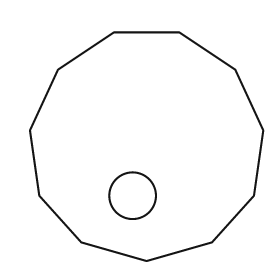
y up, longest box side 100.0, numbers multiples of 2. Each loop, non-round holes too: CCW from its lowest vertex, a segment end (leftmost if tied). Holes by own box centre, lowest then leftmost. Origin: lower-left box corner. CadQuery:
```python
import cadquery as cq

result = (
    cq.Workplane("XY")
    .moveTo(50.0, 0.0)
    .lineTo(78.0, 8.0)
    .lineTo(96.0, 28.0)
    .lineTo(100.0, 56.0)
    .lineTo(88.0, 82.0)
    .lineTo(64.0, 98.0)
    .lineTo(36.0, 98.0)
    .lineTo(12.0, 82.0)
    .lineTo(0.0, 56.0)
    .lineTo(4.0, 28.0)
    .lineTo(22.0, 8.0)
    .close()
    .moveTo(44.0, 28.0)
    .circle(10.0)
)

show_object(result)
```